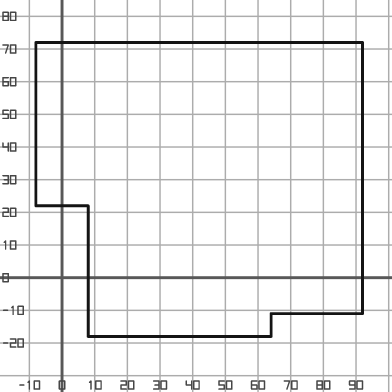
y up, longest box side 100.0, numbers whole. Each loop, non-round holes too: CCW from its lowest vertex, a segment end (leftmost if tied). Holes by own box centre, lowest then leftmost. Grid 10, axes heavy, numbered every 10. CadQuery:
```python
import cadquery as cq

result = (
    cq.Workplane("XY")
    .moveTo(8.0, -18.0)
    .lineTo(64.0, -18.0)
    .lineTo(64.0, -11.0)
    .lineTo(92.0, -11.0)
    .lineTo(92.0, 72.0)
    .lineTo(-8.0, 72.0)
    .lineTo(-8.0, 22.0)
    .lineTo(8.0, 22.0)
    .close()
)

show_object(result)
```